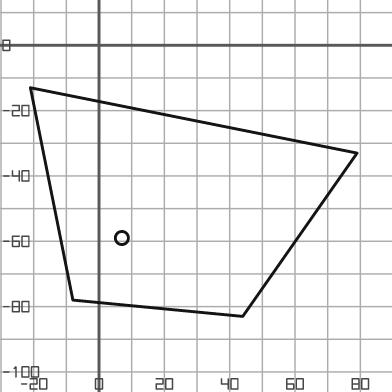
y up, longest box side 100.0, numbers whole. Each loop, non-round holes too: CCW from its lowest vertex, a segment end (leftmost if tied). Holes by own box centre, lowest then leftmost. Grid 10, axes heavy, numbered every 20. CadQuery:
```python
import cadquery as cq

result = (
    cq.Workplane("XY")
    .moveTo(44.0, -83.0)
    .lineTo(79.0, -33.0)
    .lineTo(-21.0, -13.0)
    .lineTo(-8.0, -78.0)
    .close()
    .moveTo(7.0, -59.0)
    .circle(2.0)
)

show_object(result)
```